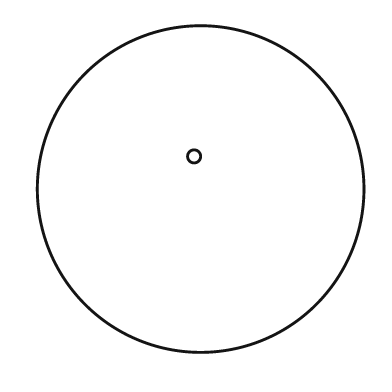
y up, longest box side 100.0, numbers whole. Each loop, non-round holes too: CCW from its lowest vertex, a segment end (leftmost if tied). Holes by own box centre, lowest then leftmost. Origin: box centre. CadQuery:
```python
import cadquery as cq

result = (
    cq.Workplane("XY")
    .moveTo(0.0, 0.0)
    .circle(50.0)
    .moveTo(-2.0, 10.0)
    .circle(2.0)
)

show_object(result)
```